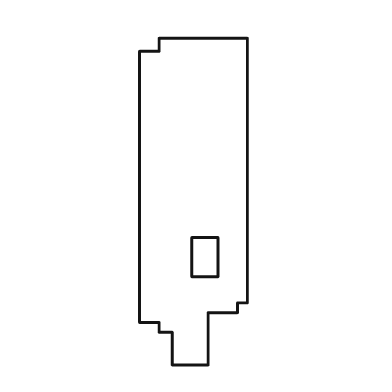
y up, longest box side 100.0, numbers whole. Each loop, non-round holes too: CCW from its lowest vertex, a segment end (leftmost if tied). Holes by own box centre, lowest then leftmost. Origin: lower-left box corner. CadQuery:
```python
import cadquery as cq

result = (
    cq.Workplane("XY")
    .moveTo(10.0, 0.0)
    .lineTo(21.0, 0.0)
    .lineTo(21.0, 16.0)
    .lineTo(30.0, 16.0)
    .lineTo(30.0, 19.0)
    .lineTo(33.0, 19.0)
    .lineTo(33.0, 100.0)
    .lineTo(6.0, 100.0)
    .lineTo(6.0, 96.0)
    .lineTo(0.0, 96.0)
    .lineTo(0.0, 13.0)
    .lineTo(6.0, 13.0)
    .lineTo(6.0, 10.0)
    .lineTo(10.0, 10.0)
    .close()
    .moveTo(16.0, 27.0)
    .lineTo(24.0, 27.0)
    .lineTo(24.0, 39.0)
    .lineTo(16.0, 39.0)
    .close()
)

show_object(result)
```